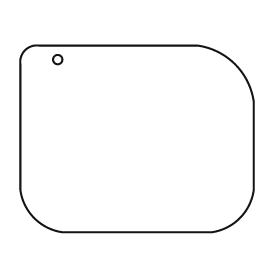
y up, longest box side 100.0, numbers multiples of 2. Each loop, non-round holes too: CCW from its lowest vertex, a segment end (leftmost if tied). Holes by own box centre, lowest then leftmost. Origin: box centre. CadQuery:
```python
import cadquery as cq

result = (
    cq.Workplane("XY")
    .moveTo(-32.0, -40.0)
    .lineTo(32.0, -40.0)
    .threePointArc((44.0, -34.0), (50.0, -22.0))
    .lineTo(50.0, 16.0)
    .threePointArc((42.0, 32.0), (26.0, 40.0))
    .lineTo(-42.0, 40.0)
    .threePointArc((-48.0, 38.0), (-50.0, 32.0))
    .lineTo(-50.0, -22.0)
    .threePointArc((-44.0, -34.0), (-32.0, -40.0))
    .close()
    .moveTo(-34.0, 34.0)
    .circle(2.0)
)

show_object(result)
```